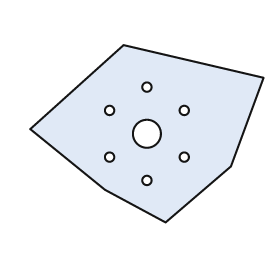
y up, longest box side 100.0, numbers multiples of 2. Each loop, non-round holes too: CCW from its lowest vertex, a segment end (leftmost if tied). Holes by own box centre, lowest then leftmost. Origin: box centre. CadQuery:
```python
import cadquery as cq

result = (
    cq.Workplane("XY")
    .moveTo(8.0, -38.0)
    .lineTo(36.0, -14.0)
    .lineTo(50.0, 24.0)
    .lineTo(-10.0, 38.0)
    .lineTo(-50.0, 2.0)
    .lineTo(-18.0, -24.0)
    .close()
    .moveTo(0.0, -20.0)
    .circle(2.0)
    .moveTo(-16.0, -10.0)
    .circle(2.0)
    .moveTo(16.0, -10.0)
    .circle(2.0)
    .moveTo(0.0, 0.0)
    .circle(6.0)
    .moveTo(-16.0, 10.0)
    .circle(2.0)
    .moveTo(16.0, 10.0)
    .circle(2.0)
    .moveTo(0.0, 20.0)
    .circle(2.0)
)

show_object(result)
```